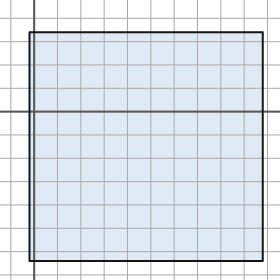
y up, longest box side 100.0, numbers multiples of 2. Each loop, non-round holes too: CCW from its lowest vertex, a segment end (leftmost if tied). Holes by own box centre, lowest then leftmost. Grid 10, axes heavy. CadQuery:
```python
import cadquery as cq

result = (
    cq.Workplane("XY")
    .moveTo(-2.0, -64.0)
    .lineTo(98.0, -64.0)
    .lineTo(98.0, 34.0)
    .lineTo(-2.0, 34.0)
    .close()
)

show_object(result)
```